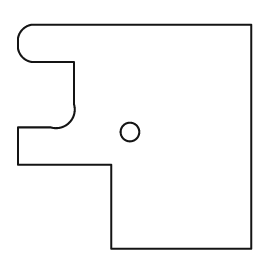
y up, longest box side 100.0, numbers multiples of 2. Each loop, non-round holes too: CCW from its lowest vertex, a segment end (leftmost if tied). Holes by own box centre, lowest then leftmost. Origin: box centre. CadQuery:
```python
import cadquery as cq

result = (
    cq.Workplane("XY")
    .moveTo(-10.0, -48.0)
    .lineTo(50.0, -48.0)
    .lineTo(50.0, 48.0)
    .lineTo(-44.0, 48.0)
    .threePointArc((-48.0, 46.0), (-50.0, 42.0))
    .lineTo(-50.0, 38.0)
    .threePointArc((-48.0, 34.0), (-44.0, 32.0))
    .lineTo(-26.0, 32.0)
    .lineTo(-26.0, 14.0)
    .threePointArc((-28.0, 6.0), (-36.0, 4.0))
    .lineTo(-50.0, 4.0)
    .lineTo(-50.0, -12.0)
    .lineTo(-10.0, -12.0)
    .close()
    .moveTo(-2.0, 2.0)
    .circle(4.0)
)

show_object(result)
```